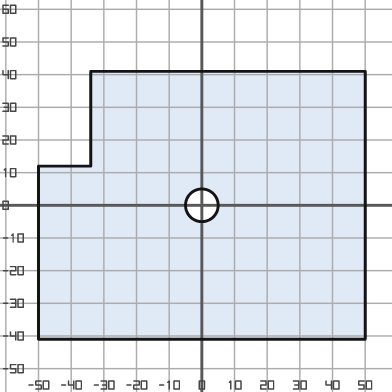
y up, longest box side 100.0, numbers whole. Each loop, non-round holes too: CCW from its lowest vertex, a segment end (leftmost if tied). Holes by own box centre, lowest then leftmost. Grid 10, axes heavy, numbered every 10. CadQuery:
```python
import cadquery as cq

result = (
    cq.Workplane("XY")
    .moveTo(-50.0, -41.0)
    .lineTo(50.0, -41.0)
    .lineTo(50.0, 41.0)
    .lineTo(-34.0, 41.0)
    .lineTo(-34.0, 12.0)
    .lineTo(-50.0, 12.0)
    .close()
    .moveTo(0.0, 0.0)
    .circle(5.0)
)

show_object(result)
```